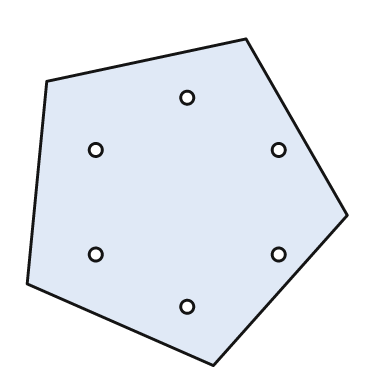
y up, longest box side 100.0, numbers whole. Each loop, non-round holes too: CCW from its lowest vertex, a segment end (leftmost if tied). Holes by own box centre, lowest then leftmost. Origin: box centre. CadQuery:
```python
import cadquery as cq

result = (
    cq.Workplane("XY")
    .moveTo(8.0, -50.0)
    .lineTo(49.0, -4.0)
    .lineTo(18.0, 50.0)
    .lineTo(-43.0, 37.0)
    .lineTo(-49.0, -25.0)
    .close()
    .moveTo(0.0, -32.0)
    .circle(2.0)
    .moveTo(-28.0, -16.0)
    .circle(2.0)
    .moveTo(28.0, -16.0)
    .circle(2.0)
    .moveTo(-28.0, 16.0)
    .circle(2.0)
    .moveTo(28.0, 16.0)
    .circle(2.0)
    .moveTo(0.0, 32.0)
    .circle(2.0)
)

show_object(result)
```